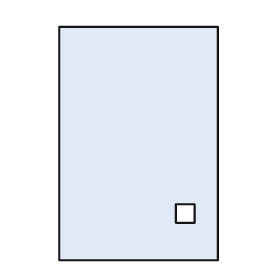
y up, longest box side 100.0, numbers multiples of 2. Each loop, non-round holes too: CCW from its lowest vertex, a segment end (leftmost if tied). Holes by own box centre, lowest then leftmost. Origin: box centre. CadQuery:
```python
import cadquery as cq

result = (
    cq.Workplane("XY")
    .moveTo(-34.0, -50.0)
    .lineTo(34.0, -50.0)
    .lineTo(34.0, 50.0)
    .lineTo(-34.0, 50.0)
    .close()
    .moveTo(16.0, -34.0)
    .lineTo(24.0, -34.0)
    .lineTo(24.0, -26.0)
    .lineTo(16.0, -26.0)
    .close()
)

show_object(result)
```